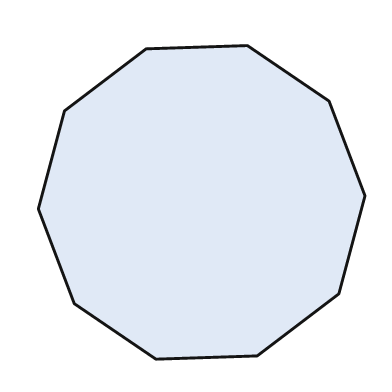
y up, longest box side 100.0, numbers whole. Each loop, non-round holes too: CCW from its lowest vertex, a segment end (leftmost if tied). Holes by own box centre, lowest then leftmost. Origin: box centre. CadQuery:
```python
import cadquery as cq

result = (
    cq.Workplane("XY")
    .moveTo(-14.0, -48.0)
    .lineTo(17.0, -47.0)
    .lineTo(42.0, -28.0)
    .lineTo(50.0, 2.0)
    .lineTo(39.0, 31.0)
    .lineTo(14.0, 48.0)
    .lineTo(-17.0, 47.0)
    .lineTo(-42.0, 28.0)
    .lineTo(-50.0, -2.0)
    .lineTo(-39.0, -31.0)
    .close()
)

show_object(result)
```